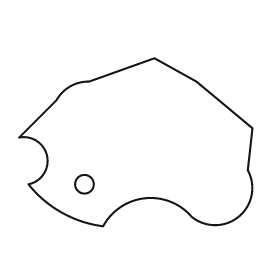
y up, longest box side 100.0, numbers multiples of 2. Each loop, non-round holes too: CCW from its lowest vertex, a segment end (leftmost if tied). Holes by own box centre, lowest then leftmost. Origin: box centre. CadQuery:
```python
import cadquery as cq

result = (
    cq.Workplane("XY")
    .moveTo(-14.0, -36.0)
    .threePointArc((4.0, -24.0), (24.0, -32.0))
    .threePointArc((44.0, -32.0), (48.0, -12.0))
    .lineTo(50.0, 6.0)
    .lineTo(26.0, 26.0)
    .lineTo(8.0, 36.0)
    .lineTo(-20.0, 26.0)
    .threePointArc((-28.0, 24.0), (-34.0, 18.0))
    .lineTo(-50.0, 2.0)
    .threePointArc((-38.0, -6.0), (-46.0, -18.0))
    .threePointArc((-32.0, -30.0), (-14.0, -36.0))
    .close()
    .moveTo(-22.0, -18.0)
    .circle(4.0)
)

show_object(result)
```